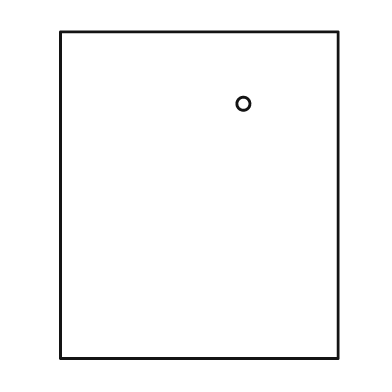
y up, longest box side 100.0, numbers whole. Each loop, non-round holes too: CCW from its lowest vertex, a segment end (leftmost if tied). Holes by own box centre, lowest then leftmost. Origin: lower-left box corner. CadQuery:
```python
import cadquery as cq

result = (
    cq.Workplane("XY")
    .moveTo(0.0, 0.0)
    .lineTo(85.0, 0.0)
    .lineTo(85.0, 100.0)
    .lineTo(0.0, 100.0)
    .close()
    .moveTo(56.0, 78.0)
    .circle(2.0)
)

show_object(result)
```